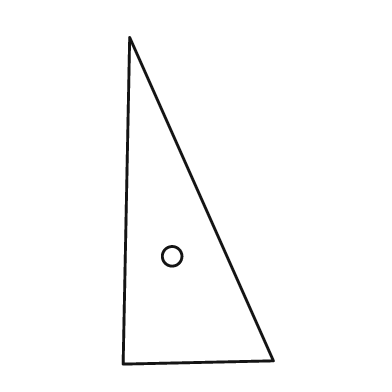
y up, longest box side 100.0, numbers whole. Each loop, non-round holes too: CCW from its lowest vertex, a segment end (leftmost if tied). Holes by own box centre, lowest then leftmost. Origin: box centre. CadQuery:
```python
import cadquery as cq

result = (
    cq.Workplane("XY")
    .moveTo(-23.0, -50.0)
    .lineTo(23.0, -49.0)
    .lineTo(-21.0, 50.0)
    .close()
    .moveTo(-8.0, -17.0)
    .circle(3.0)
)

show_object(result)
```